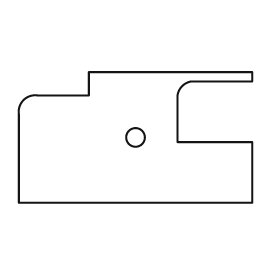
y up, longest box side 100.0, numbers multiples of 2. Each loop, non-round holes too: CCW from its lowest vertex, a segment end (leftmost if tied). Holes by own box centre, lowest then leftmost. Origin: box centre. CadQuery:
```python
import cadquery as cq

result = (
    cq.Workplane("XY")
    .moveTo(-50.0, -28.0)
    .lineTo(50.0, -28.0)
    .lineTo(50.0, -2.0)
    .lineTo(18.0, -2.0)
    .lineTo(18.0, 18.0)
    .threePointArc((20.0, 22.0), (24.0, 24.0))
    .lineTo(50.0, 24.0)
    .lineTo(50.0, 28.0)
    .lineTo(-20.0, 28.0)
    .lineTo(-20.0, 18.0)
    .lineTo(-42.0, 18.0)
    .threePointArc((-48.0, 16.0), (-50.0, 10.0))
    .close()
    .moveTo(0.0, 0.0)
    .circle(4.0)
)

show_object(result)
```